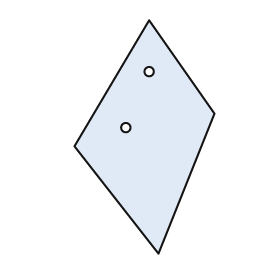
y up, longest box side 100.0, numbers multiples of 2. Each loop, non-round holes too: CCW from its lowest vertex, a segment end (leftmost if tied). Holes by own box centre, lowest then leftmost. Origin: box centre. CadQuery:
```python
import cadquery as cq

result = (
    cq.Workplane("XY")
    .moveTo(6.0, -50.0)
    .lineTo(30.0, 10.0)
    .lineTo(2.0, 50.0)
    .lineTo(-30.0, -4.0)
    .close()
    .moveTo(-8.0, 4.0)
    .circle(2.0)
    .moveTo(2.0, 28.0)
    .circle(2.0)
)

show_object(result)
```